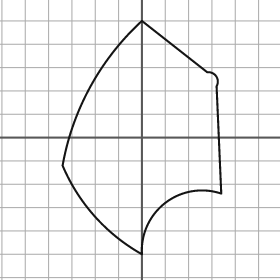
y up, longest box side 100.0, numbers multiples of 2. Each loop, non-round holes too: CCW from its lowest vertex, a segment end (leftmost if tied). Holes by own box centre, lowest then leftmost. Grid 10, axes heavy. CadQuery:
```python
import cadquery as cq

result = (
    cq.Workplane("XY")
    .moveTo(0.0, -50.0)
    .threePointArc((10.0, -28.0), (34.0, -24.0))
    .lineTo(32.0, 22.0)
    .threePointArc((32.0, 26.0), (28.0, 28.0))
    .lineTo(0.0, 50.0)
    .threePointArc((-22.0, 22.0), (-34.0, -12.0))
    .threePointArc((-20.0, -34.0), (0.0, -50.0))
    .close()
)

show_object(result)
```